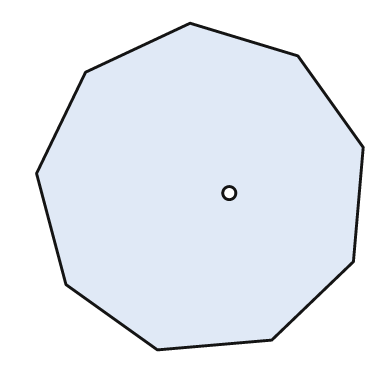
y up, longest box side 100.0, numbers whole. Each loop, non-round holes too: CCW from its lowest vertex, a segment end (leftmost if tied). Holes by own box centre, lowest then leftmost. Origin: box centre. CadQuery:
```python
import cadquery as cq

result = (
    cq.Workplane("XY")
    .moveTo(-13.0, -50.0)
    .lineTo(22.0, -47.0)
    .lineTo(47.0, -23.0)
    .lineTo(50.0, 12.0)
    .lineTo(30.0, 40.0)
    .lineTo(-3.0, 50.0)
    .lineTo(-35.0, 35.0)
    .lineTo(-50.0, 4.0)
    .lineTo(-41.0, -30.0)
    .close()
    .moveTo(9.0, -2.0)
    .circle(2.0)
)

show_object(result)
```